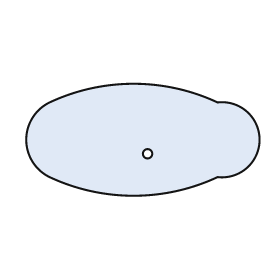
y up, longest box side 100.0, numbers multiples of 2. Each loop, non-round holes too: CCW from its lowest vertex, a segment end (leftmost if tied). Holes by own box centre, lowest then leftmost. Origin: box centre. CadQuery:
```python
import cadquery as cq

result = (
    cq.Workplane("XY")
    .moveTo(-40.0, -16.0)
    .threePointArc((-4.0, -24.0), (32.0, -16.0))
    .threePointArc((50.0, 0.0), (32.0, 16.0))
    .threePointArc((-4.0, 24.0), (-40.0, 16.0))
    .threePointArc((-50.0, 0.0), (-40.0, -16.0))
    .close()
    .moveTo(2.0, -6.0)
    .circle(2.0)
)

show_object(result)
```